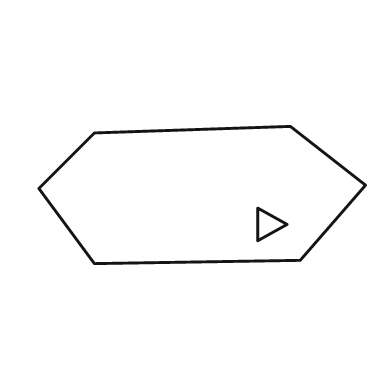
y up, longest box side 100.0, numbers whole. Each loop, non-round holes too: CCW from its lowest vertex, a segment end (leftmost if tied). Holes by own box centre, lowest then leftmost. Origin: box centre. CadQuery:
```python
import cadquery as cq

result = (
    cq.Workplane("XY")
    .moveTo(-33.0, -21.0)
    .lineTo(30.0, -20.0)
    .lineTo(50.0, 3.0)
    .lineTo(27.0, 21.0)
    .lineTo(-33.0, 19.0)
    .lineTo(-50.0, 2.0)
    .close()
    .moveTo(17.0, -14.0)
    .lineTo(26.0, -9.0)
    .lineTo(17.0, -4.0)
    .close()
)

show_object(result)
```